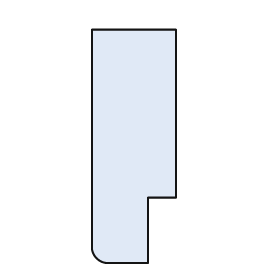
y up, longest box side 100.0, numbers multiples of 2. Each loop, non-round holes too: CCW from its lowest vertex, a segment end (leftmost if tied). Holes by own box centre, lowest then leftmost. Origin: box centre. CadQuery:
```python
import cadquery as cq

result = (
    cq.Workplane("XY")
    .moveTo(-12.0, -50.0)
    .lineTo(6.0, -50.0)
    .lineTo(6.0, -22.0)
    .lineTo(18.0, -22.0)
    .lineTo(18.0, 50.0)
    .lineTo(-18.0, 50.0)
    .lineTo(-18.0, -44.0)
    .threePointArc((-16.0, -48.0), (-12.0, -50.0))
    .close()
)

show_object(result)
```